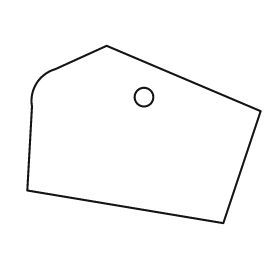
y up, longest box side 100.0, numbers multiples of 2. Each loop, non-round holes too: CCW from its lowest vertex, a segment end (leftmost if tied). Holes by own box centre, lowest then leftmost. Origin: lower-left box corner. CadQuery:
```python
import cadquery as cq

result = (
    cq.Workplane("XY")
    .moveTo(84.0, 0.0)
    .lineTo(100.0, 48.0)
    .lineTo(34.0, 76.0)
    .lineTo(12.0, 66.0)
    .threePointArc((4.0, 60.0), (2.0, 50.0))
    .lineTo(0.0, 14.0)
    .close()
    .moveTo(50.0, 54.0)
    .circle(4.0)
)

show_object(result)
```